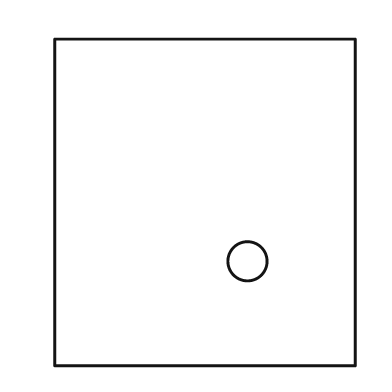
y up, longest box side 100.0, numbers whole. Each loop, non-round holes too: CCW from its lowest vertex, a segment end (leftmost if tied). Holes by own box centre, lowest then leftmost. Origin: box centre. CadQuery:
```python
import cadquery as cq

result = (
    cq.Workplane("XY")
    .moveTo(-46.0, -50.0)
    .lineTo(46.0, -50.0)
    .lineTo(46.0, 50.0)
    .lineTo(-46.0, 50.0)
    .close()
    .moveTo(13.0, -18.0)
    .circle(6.0)
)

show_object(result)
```